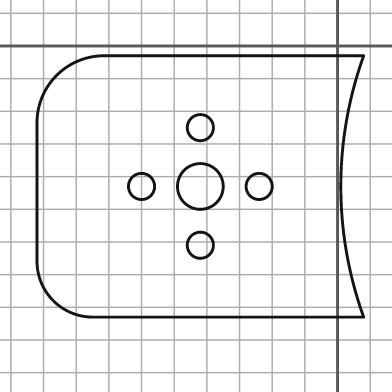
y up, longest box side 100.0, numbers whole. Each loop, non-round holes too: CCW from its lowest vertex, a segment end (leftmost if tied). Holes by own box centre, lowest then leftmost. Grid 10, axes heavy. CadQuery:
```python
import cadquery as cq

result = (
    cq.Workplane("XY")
    .moveTo(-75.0, -83.0)
    .lineTo(8.0, -83.0)
    .threePointArc((1.0, -43.0), (8.0, -3.0))
    .lineTo(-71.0, -3.0)
    .threePointArc((-86.0, -9.0), (-92.0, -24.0))
    .lineTo(-92.0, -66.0)
    .threePointArc((-87.0, -78.0), (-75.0, -83.0))
    .close()
    .moveTo(-42.0, -61.0)
    .circle(4.0)
    .moveTo(-60.0, -43.0)
    .circle(4.0)
    .moveTo(-42.0, -43.0)
    .circle(7.0)
    .moveTo(-24.0, -43.0)
    .circle(4.0)
    .moveTo(-42.0, -25.0)
    .circle(4.0)
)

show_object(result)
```